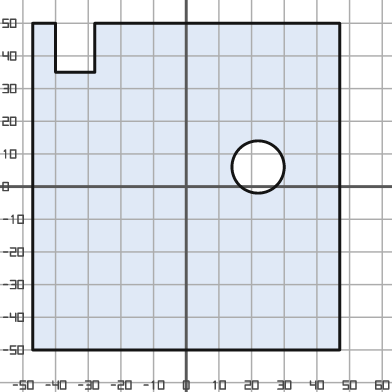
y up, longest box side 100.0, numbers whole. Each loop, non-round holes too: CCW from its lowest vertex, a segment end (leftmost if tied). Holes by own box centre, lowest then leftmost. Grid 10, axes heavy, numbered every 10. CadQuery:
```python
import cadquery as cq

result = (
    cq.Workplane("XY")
    .moveTo(-47.0, -50.0)
    .lineTo(47.0, -50.0)
    .lineTo(47.0, 50.0)
    .lineTo(-28.0, 50.0)
    .lineTo(-28.0, 35.0)
    .lineTo(-40.0, 35.0)
    .lineTo(-40.0, 50.0)
    .lineTo(-47.0, 50.0)
    .close()
    .moveTo(22.0, 6.0)
    .circle(8.0)
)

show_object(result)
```